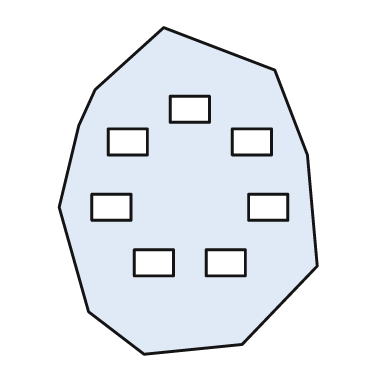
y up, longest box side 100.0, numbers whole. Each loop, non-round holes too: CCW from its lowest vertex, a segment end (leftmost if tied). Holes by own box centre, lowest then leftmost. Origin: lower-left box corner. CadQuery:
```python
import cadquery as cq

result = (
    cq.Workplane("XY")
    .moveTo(26.0, 0.0)
    .lineTo(56.0, 3.0)
    .lineTo(79.0, 27.0)
    .lineTo(76.0, 61.0)
    .lineTo(66.0, 87.0)
    .lineTo(32.0, 100.0)
    .lineTo(11.0, 81.0)
    .lineTo(6.0, 70.0)
    .lineTo(0.0, 45.0)
    .lineTo(9.0, 13.0)
    .close()
    .moveTo(23.0, 24.0)
    .lineTo(35.0, 24.0)
    .lineTo(35.0, 32.0)
    .lineTo(23.0, 32.0)
    .close()
    .moveTo(45.0, 24.0)
    .lineTo(57.0, 24.0)
    .lineTo(57.0, 32.0)
    .lineTo(45.0, 32.0)
    .close()
    .moveTo(10.0, 41.0)
    .lineTo(22.0, 41.0)
    .lineTo(22.0, 49.0)
    .lineTo(10.0, 49.0)
    .close()
    .moveTo(58.0, 41.0)
    .lineTo(70.0, 41.0)
    .lineTo(70.0, 49.0)
    .lineTo(58.0, 49.0)
    .close()
    .moveTo(15.0, 61.0)
    .lineTo(27.0, 61.0)
    .lineTo(27.0, 69.0)
    .lineTo(15.0, 69.0)
    .close()
    .moveTo(53.0, 61.0)
    .lineTo(65.0, 61.0)
    .lineTo(65.0, 69.0)
    .lineTo(53.0, 69.0)
    .close()
    .moveTo(34.0, 71.0)
    .lineTo(46.0, 71.0)
    .lineTo(46.0, 79.0)
    .lineTo(34.0, 79.0)
    .close()
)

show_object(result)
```